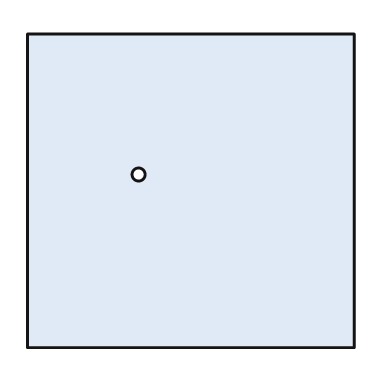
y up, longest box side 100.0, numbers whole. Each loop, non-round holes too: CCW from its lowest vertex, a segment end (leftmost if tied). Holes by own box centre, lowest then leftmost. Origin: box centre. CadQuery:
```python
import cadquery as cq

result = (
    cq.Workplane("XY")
    .moveTo(-50.0, -48.0)
    .lineTo(50.0, -48.0)
    .lineTo(50.0, 48.0)
    .lineTo(-50.0, 48.0)
    .close()
    .moveTo(-16.0, 5.0)
    .circle(2.0)
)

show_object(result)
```